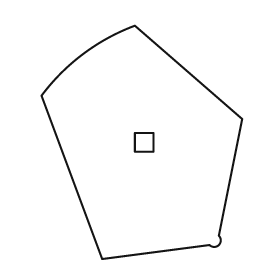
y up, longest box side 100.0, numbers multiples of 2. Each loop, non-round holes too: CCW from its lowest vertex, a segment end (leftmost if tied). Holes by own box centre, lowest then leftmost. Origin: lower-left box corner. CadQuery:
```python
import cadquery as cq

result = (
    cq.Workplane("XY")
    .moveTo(26.0, 0.0)
    .lineTo(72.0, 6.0)
    .threePointArc((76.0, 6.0), (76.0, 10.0))
    .lineTo(86.0, 60.0)
    .lineTo(40.0, 100.0)
    .threePointArc((18.0, 88.0), (0.0, 70.0))
    .close()
    .moveTo(40.0, 46.0)
    .lineTo(48.0, 46.0)
    .lineTo(48.0, 54.0)
    .lineTo(40.0, 54.0)
    .close()
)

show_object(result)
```